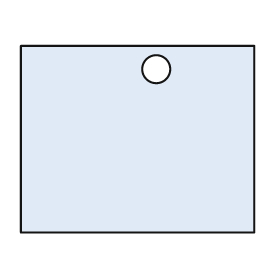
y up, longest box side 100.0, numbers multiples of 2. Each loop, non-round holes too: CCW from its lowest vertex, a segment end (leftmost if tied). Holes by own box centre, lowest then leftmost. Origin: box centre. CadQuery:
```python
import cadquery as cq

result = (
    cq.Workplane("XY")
    .moveTo(-50.0, -40.0)
    .lineTo(50.0, -40.0)
    .lineTo(50.0, 40.0)
    .lineTo(-50.0, 40.0)
    .close()
    .moveTo(8.0, 30.0)
    .circle(6.0)
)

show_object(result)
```